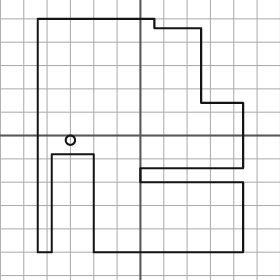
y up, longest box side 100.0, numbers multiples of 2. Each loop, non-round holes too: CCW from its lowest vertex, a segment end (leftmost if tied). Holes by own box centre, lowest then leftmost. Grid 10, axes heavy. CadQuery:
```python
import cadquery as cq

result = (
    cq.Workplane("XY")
    .moveTo(-44.0, -50.0)
    .lineTo(-38.0, -50.0)
    .lineTo(-38.0, -8.0)
    .lineTo(-20.0, -8.0)
    .lineTo(-20.0, -50.0)
    .lineTo(44.0, -50.0)
    .lineTo(44.0, -20.0)
    .lineTo(0.0, -20.0)
    .lineTo(0.0, -14.0)
    .lineTo(44.0, -14.0)
    .lineTo(44.0, 14.0)
    .lineTo(26.0, 14.0)
    .lineTo(26.0, 46.0)
    .lineTo(6.0, 46.0)
    .lineTo(6.0, 50.0)
    .lineTo(-44.0, 50.0)
    .close()
    .moveTo(-30.0, -2.0)
    .circle(2.0)
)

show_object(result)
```